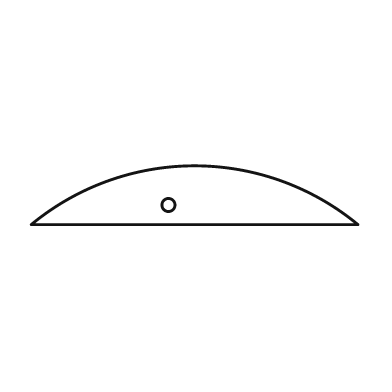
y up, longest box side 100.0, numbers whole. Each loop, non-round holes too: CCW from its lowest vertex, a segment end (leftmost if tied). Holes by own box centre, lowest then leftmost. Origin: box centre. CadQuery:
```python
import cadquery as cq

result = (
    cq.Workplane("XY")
    .moveTo(-50.0, -9.0)
    .lineTo(50.0, -9.0)
    .threePointArc((0.0, 9.0), (-50.0, -9.0))
    .close()
    .moveTo(-8.0, -3.0)
    .circle(2.0)
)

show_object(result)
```